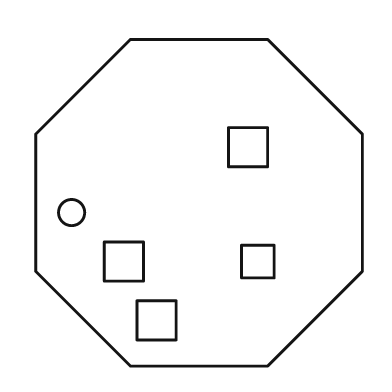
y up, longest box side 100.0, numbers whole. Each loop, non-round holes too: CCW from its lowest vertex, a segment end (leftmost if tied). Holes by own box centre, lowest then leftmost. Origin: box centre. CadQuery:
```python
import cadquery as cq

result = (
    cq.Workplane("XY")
    .moveTo(-21.0, -50.0)
    .lineTo(21.0, -50.0)
    .lineTo(50.0, -21.0)
    .lineTo(50.0, 21.0)
    .lineTo(21.0, 50.0)
    .lineTo(-21.0, 50.0)
    .lineTo(-50.0, 21.0)
    .lineTo(-50.0, -21.0)
    .close()
    .moveTo(-19.0, -42.0)
    .lineTo(-7.0, -42.0)
    .lineTo(-7.0, -30.0)
    .lineTo(-19.0, -30.0)
    .close()
    .moveTo(-29.0, -24.0)
    .lineTo(-17.0, -24.0)
    .lineTo(-17.0, -12.0)
    .lineTo(-29.0, -12.0)
    .close()
    .moveTo(13.0, -23.0)
    .lineTo(23.0, -23.0)
    .lineTo(23.0, -13.0)
    .lineTo(13.0, -13.0)
    .close()
    .moveTo(-39.0, -3.0)
    .circle(4.0)
    .moveTo(9.0, 11.0)
    .lineTo(21.0, 11.0)
    .lineTo(21.0, 23.0)
    .lineTo(9.0, 23.0)
    .close()
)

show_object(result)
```